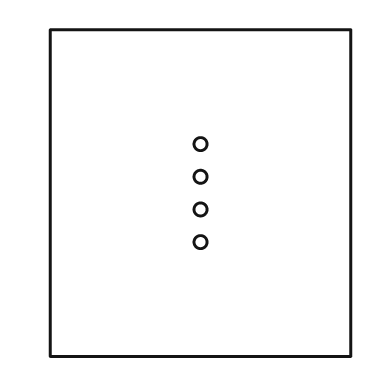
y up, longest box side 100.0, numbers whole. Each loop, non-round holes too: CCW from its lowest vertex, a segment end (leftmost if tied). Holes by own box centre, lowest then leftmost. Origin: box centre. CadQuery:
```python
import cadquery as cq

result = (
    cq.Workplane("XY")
    .moveTo(-46.0, -50.0)
    .lineTo(46.0, -50.0)
    .lineTo(46.0, 50.0)
    .lineTo(-46.0, 50.0)
    .close()
    .moveTo(0.0, -15.0)
    .circle(2.0)
    .moveTo(0.0, -5.0)
    .circle(2.0)
    .moveTo(0.0, 5.0)
    .circle(2.0)
    .moveTo(0.0, 15.0)
    .circle(2.0)
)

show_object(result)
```